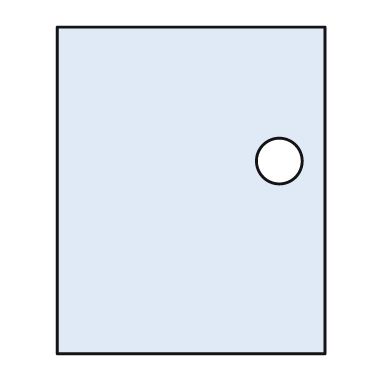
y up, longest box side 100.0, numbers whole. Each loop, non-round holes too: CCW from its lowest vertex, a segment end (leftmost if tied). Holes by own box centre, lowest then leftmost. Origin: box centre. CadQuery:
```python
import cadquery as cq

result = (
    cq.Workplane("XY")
    .moveTo(-41.0, -50.0)
    .lineTo(41.0, -50.0)
    .lineTo(41.0, 50.0)
    .lineTo(-41.0, 50.0)
    .close()
    .moveTo(27.0, 9.0)
    .circle(7.0)
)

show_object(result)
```